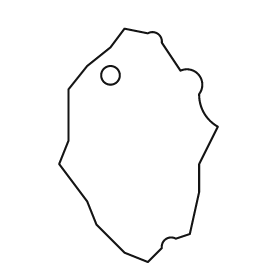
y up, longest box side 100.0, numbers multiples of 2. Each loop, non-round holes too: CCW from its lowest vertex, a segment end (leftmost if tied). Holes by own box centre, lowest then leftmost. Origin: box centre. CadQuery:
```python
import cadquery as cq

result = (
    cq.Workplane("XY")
    .moveTo(4.0, -50.0)
    .lineTo(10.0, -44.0)
    .threePointArc((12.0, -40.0), (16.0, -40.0))
    .lineTo(22.0, -38.0)
    .lineTo(26.0, -20.0)
    .lineTo(26.0, -8.0)
    .lineTo(34.0, 8.0)
    .threePointArc((28.0, 14.0), (26.0, 22.0))
    .threePointArc((26.0, 30.0), (18.0, 32.0))
    .lineTo(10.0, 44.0)
    .threePointArc((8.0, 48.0), (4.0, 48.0))
    .lineTo(-6.0, 50.0)
    .lineTo(-12.0, 42.0)
    .lineTo(-22.0, 34.0)
    .lineTo(-30.0, 24.0)
    .lineTo(-30.0, 2.0)
    .lineTo(-34.0, -8.0)
    .lineTo(-22.0, -24.0)
    .lineTo(-18.0, -34.0)
    .lineTo(-6.0, -46.0)
    .close()
    .moveTo(-12.0, 30.0)
    .circle(4.0)
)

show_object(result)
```